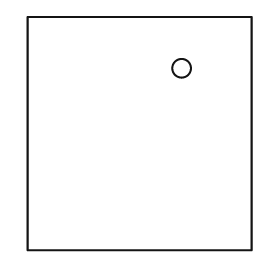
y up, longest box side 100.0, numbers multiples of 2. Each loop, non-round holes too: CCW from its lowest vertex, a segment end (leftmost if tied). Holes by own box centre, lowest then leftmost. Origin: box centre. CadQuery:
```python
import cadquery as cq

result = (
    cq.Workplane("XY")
    .moveTo(-48.0, -50.0)
    .lineTo(48.0, -50.0)
    .lineTo(48.0, 50.0)
    .lineTo(-48.0, 50.0)
    .close()
    .moveTo(18.0, 28.0)
    .circle(4.0)
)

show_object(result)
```